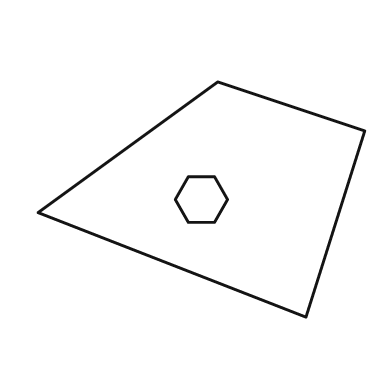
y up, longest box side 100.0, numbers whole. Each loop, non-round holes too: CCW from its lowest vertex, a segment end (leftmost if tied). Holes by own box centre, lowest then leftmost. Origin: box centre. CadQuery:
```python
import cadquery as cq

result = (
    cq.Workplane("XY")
    .moveTo(32.0, -36.0)
    .lineTo(50.0, 21.0)
    .lineTo(5.0, 36.0)
    .lineTo(-50.0, -4.0)
    .close()
    .moveTo(-4.0, -7.0)
    .lineTo(4.0, -7.0)
    .lineTo(8.0, 0.0)
    .lineTo(4.0, 7.0)
    .lineTo(-4.0, 7.0)
    .lineTo(-8.0, 0.0)
    .close()
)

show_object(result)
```